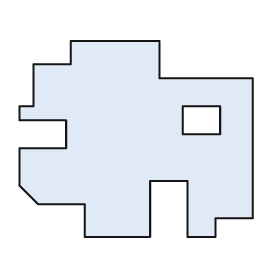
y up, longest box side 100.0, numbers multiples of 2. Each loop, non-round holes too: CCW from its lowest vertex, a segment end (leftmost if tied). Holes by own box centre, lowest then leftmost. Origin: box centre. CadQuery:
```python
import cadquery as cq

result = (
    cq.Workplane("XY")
    .moveTo(-22.0, -42.0)
    .lineTo(6.0, -42.0)
    .lineTo(6.0, -18.0)
    .lineTo(22.0, -18.0)
    .lineTo(22.0, -42.0)
    .lineTo(34.0, -42.0)
    .lineTo(34.0, -34.0)
    .lineTo(50.0, -34.0)
    .lineTo(50.0, 26.0)
    .lineTo(10.0, 26.0)
    .lineTo(10.0, 42.0)
    .lineTo(-28.0, 42.0)
    .lineTo(-28.0, 32.0)
    .lineTo(-44.0, 32.0)
    .lineTo(-44.0, 14.0)
    .lineTo(-50.0, 14.0)
    .lineTo(-50.0, 8.0)
    .lineTo(-30.0, 8.0)
    .lineTo(-30.0, -4.0)
    .lineTo(-50.0, -4.0)
    .lineTo(-50.0, -20.0)
    .lineTo(-42.0, -28.0)
    .lineTo(-22.0, -28.0)
    .close()
    .moveTo(20.0, 2.0)
    .lineTo(36.0, 2.0)
    .lineTo(36.0, 14.0)
    .lineTo(20.0, 14.0)
    .close()
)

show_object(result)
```